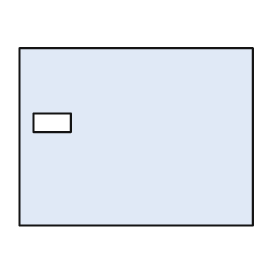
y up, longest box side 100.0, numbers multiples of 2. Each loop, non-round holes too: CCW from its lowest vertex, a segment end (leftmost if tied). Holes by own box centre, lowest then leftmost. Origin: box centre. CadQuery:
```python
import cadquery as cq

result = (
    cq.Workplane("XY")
    .moveTo(-50.0, -38.0)
    .lineTo(50.0, -38.0)
    .lineTo(50.0, 38.0)
    .lineTo(-50.0, 38.0)
    .close()
    .moveTo(-44.0, 2.0)
    .lineTo(-28.0, 2.0)
    .lineTo(-28.0, 10.0)
    .lineTo(-44.0, 10.0)
    .close()
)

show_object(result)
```